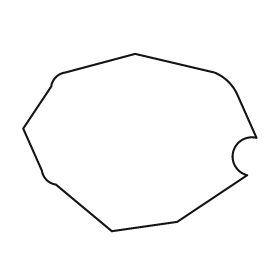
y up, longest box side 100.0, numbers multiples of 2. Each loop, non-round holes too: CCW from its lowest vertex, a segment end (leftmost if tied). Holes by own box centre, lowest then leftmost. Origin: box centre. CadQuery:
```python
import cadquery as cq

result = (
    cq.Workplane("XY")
    .moveTo(-12.0, -38.0)
    .lineTo(16.0, -34.0)
    .lineTo(46.0, -14.0)
    .threePointArc((40.0, -4.0), (50.0, 2.0))
    .lineTo(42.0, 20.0)
    .threePointArc((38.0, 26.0), (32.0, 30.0))
    .lineTo(-2.0, 38.0)
    .lineTo(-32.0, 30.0)
    .threePointArc((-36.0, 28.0), (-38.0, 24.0))
    .lineTo(-50.0, 6.0)
    .lineTo(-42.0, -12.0)
    .threePointArc((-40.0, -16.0), (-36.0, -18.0))
    .close()
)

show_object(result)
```